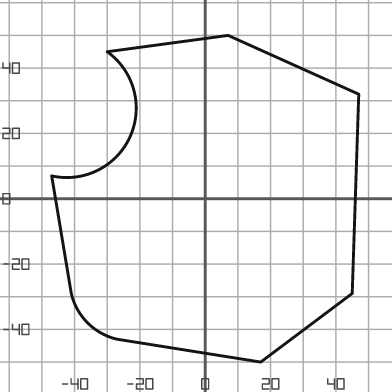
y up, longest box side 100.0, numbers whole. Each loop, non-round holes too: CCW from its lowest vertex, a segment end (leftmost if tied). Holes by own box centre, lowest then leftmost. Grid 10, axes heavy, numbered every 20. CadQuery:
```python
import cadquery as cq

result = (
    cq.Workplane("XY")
    .moveTo(17.0, -50.0)
    .lineTo(45.0, -29.0)
    .lineTo(47.0, 32.0)
    .lineTo(7.0, 50.0)
    .lineTo(-30.0, 45.0)
    .threePointArc((-23.0, 19.0), (-47.0, 7.0))
    .lineTo(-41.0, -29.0)
    .threePointArc((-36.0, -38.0), (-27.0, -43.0))
    .close()
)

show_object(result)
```